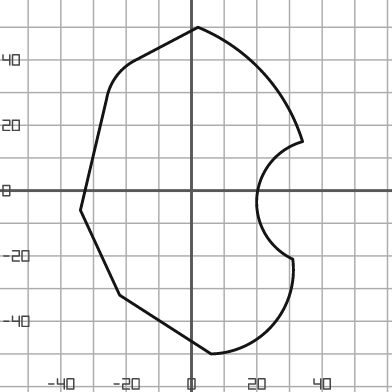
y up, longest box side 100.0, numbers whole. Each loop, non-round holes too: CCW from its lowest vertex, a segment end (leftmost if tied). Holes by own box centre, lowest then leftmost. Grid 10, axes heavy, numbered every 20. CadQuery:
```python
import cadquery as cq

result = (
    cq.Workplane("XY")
    .moveTo(6.0, -50.0)
    .threePointArc((25.0, -41.0), (31.0, -21.0))
    .threePointArc((20.0, -2.0), (34.0, 15.0))
    .threePointArc((22.0, 36.0), (2.0, 50.0))
    .lineTo(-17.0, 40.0)
    .threePointArc((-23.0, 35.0), (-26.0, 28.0))
    .lineTo(-34.0, -6.0)
    .lineTo(-22.0, -32.0)
    .close()
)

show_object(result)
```